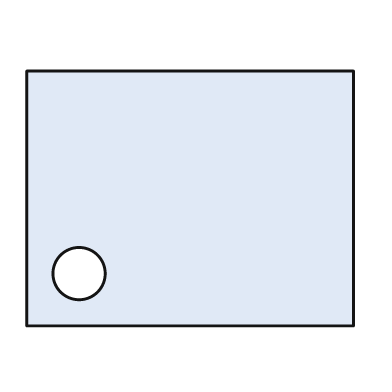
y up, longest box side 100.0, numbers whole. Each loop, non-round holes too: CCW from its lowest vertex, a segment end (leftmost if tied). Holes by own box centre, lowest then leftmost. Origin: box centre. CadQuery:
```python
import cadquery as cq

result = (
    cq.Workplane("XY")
    .moveTo(-50.0, -39.0)
    .lineTo(50.0, -39.0)
    .lineTo(50.0, 39.0)
    .lineTo(-50.0, 39.0)
    .close()
    .moveTo(-34.0, -23.0)
    .circle(8.0)
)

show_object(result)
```